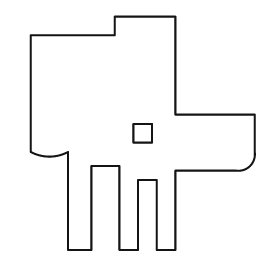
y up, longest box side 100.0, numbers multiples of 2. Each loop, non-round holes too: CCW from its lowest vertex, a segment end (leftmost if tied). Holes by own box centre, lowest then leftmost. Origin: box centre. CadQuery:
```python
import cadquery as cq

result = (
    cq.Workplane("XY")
    .moveTo(-32.0, -50.0)
    .lineTo(-22.0, -50.0)
    .lineTo(-22.0, -14.0)
    .lineTo(-10.0, -14.0)
    .lineTo(-10.0, -50.0)
    .lineTo(-2.0, -50.0)
    .lineTo(-2.0, -20.0)
    .lineTo(6.0, -20.0)
    .lineTo(6.0, -50.0)
    .lineTo(14.0, -50.0)
    .lineTo(14.0, -16.0)
    .lineTo(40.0, -16.0)
    .threePointArc((46.0, -14.0), (48.0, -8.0))
    .lineTo(48.0, 8.0)
    .lineTo(14.0, 8.0)
    .lineTo(14.0, 50.0)
    .lineTo(-12.0, 50.0)
    .lineTo(-12.0, 42.0)
    .lineTo(-48.0, 42.0)
    .lineTo(-48.0, -8.0)
    .threePointArc((-40.0, -10.0), (-32.0, -8.0))
    .close()
    .moveTo(-4.0, -4.0)
    .lineTo(4.0, -4.0)
    .lineTo(4.0, 4.0)
    .lineTo(-4.0, 4.0)
    .close()
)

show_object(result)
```